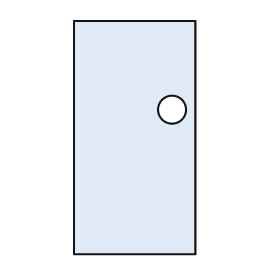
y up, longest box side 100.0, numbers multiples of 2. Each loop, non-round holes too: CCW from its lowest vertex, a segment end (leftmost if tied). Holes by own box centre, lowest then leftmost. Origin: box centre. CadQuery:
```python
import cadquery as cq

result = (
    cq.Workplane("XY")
    .moveTo(-26.0, -50.0)
    .lineTo(26.0, -50.0)
    .lineTo(26.0, 50.0)
    .lineTo(-26.0, 50.0)
    .close()
    .moveTo(16.0, 12.0)
    .circle(6.0)
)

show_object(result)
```